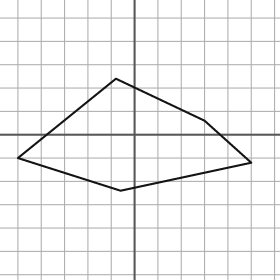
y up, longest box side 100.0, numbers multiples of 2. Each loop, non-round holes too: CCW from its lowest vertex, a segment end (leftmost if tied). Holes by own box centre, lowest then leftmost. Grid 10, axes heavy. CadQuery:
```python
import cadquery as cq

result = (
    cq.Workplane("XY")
    .moveTo(-6.0, -24.0)
    .lineTo(50.0, -12.0)
    .lineTo(30.0, 6.0)
    .lineTo(-8.0, 24.0)
    .lineTo(-50.0, -10.0)
    .close()
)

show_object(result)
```